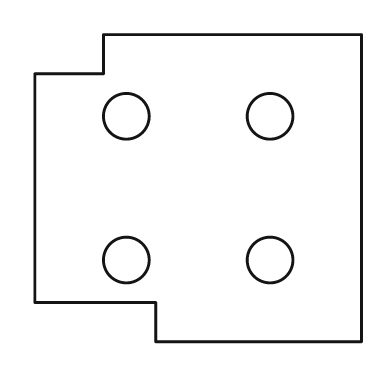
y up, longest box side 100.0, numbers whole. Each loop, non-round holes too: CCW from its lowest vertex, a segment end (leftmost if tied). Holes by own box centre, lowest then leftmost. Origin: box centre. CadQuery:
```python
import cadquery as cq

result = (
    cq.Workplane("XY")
    .moveTo(-13.0, -47.0)
    .lineTo(50.0, -47.0)
    .lineTo(50.0, 47.0)
    .lineTo(-29.0, 47.0)
    .lineTo(-29.0, 35.0)
    .lineTo(-50.0, 35.0)
    .lineTo(-50.0, -35.0)
    .lineTo(-13.0, -35.0)
    .close()
    .moveTo(-22.0, -22.0)
    .circle(7.0)
    .moveTo(22.0, -22.0)
    .circle(7.0)
    .moveTo(-22.0, 22.0)
    .circle(7.0)
    .moveTo(22.0, 22.0)
    .circle(7.0)
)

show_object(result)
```